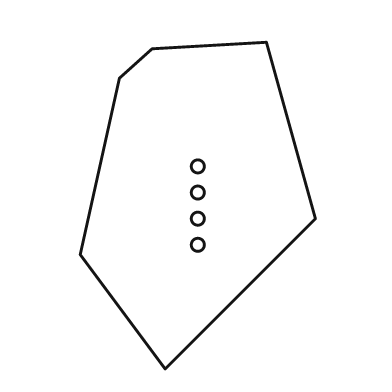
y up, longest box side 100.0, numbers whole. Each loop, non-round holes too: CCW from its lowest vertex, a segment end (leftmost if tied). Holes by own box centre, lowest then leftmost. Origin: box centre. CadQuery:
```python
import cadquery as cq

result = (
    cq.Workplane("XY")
    .moveTo(-10.0, -50.0)
    .lineTo(36.0, -4.0)
    .lineTo(21.0, 50.0)
    .lineTo(-14.0, 48.0)
    .lineTo(-24.0, 39.0)
    .lineTo(-36.0, -15.0)
    .close()
    .moveTo(0.0, -12.0)
    .circle(2.0)
    .moveTo(0.0, -4.0)
    .circle(2.0)
    .moveTo(0.0, 4.0)
    .circle(2.0)
    .moveTo(0.0, 12.0)
    .circle(2.0)
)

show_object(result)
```